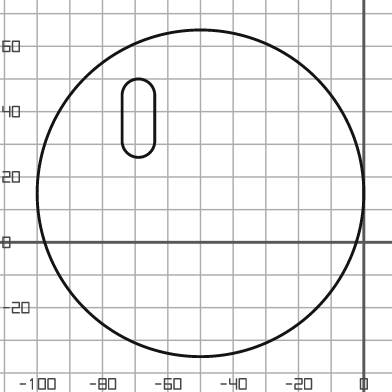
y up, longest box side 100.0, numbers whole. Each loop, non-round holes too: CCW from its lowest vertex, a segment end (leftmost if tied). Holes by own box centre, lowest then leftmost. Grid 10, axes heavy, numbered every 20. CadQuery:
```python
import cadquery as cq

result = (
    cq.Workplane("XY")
    .moveTo(-50.0, 15.0)
    .circle(50.0)
    .moveTo(-74.0, 31.0)
    .threePointArc((-69.0, 26.0), (-64.0, 31.0))
    .lineTo(-64.0, 45.0)
    .threePointArc((-69.0, 50.0), (-74.0, 45.0))
    .close()
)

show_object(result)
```